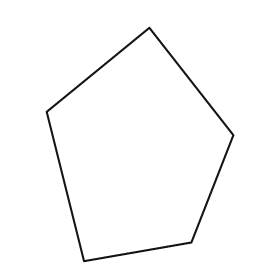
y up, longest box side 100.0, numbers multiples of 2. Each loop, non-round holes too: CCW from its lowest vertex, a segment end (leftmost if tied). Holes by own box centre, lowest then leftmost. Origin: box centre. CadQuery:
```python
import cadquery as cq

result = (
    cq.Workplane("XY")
    .moveTo(-24.0, -50.0)
    .lineTo(22.0, -42.0)
    .lineTo(40.0, 4.0)
    .lineTo(4.0, 50.0)
    .lineTo(-40.0, 14.0)
    .close()
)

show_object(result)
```